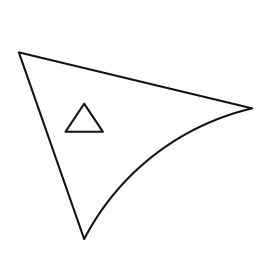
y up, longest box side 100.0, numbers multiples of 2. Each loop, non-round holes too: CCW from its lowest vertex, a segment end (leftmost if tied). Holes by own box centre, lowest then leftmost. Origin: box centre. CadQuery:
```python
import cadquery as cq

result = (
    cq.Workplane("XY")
    .moveTo(-22.0, -40.0)
    .threePointArc((8.0, -4.0), (50.0, 16.0))
    .lineTo(-50.0, 40.0)
    .close()
    .moveTo(-30.0, 6.0)
    .lineTo(-14.0, 6.0)
    .lineTo(-22.0, 18.0)
    .close()
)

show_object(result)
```